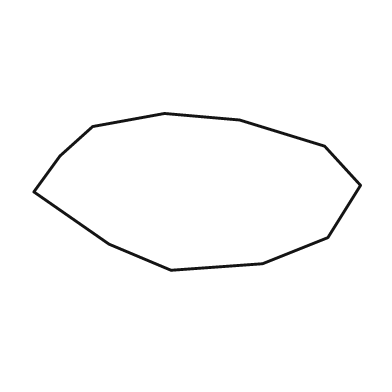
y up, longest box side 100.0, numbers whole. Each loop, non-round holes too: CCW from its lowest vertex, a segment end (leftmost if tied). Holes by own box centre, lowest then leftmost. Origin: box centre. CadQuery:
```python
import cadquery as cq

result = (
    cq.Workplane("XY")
    .moveTo(-8.0, -24.0)
    .lineTo(20.0, -22.0)
    .lineTo(40.0, -14.0)
    .lineTo(50.0, 2.0)
    .lineTo(39.0, 14.0)
    .lineTo(13.0, 22.0)
    .lineTo(-10.0, 24.0)
    .lineTo(-32.0, 20.0)
    .lineTo(-42.0, 11.0)
    .lineTo(-50.0, 0.0)
    .lineTo(-27.0, -16.0)
    .close()
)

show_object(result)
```